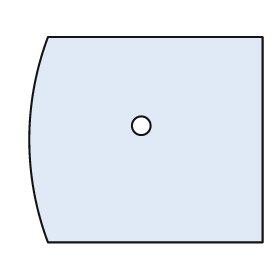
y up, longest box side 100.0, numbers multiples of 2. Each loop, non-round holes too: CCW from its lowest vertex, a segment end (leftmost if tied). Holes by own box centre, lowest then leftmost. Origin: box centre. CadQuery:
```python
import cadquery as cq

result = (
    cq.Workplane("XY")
    .moveTo(-42.0, -44.0)
    .lineTo(50.0, -44.0)
    .lineTo(50.0, 44.0)
    .lineTo(-42.0, 44.0)
    .threePointArc((-50.0, 0.0), (-42.0, -44.0))
    .close()
    .moveTo(-2.0, 6.0)
    .circle(4.0)
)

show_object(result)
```